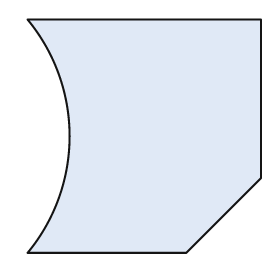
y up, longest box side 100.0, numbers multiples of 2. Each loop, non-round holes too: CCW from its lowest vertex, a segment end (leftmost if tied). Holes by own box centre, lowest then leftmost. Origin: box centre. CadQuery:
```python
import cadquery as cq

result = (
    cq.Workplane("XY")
    .moveTo(-50.0, -50.0)
    .lineTo(18.0, -50.0)
    .lineTo(50.0, -18.0)
    .lineTo(50.0, 50.0)
    .lineTo(-50.0, 50.0)
    .threePointArc((-32.0, 0.0), (-50.0, -50.0))
    .close()
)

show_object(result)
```